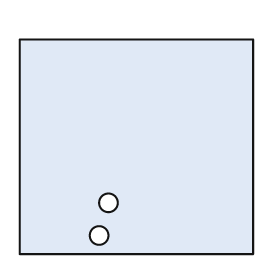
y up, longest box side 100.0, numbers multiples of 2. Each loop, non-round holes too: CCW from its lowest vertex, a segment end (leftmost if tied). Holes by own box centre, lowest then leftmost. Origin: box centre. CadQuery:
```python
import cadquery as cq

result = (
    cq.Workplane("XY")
    .moveTo(-50.0, -46.0)
    .lineTo(50.0, -46.0)
    .lineTo(50.0, 46.0)
    .lineTo(-50.0, 46.0)
    .close()
    .moveTo(-16.0, -38.0)
    .circle(4.0)
    .moveTo(-12.0, -24.0)
    .circle(4.0)
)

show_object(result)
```